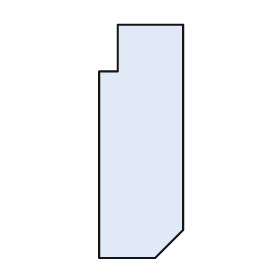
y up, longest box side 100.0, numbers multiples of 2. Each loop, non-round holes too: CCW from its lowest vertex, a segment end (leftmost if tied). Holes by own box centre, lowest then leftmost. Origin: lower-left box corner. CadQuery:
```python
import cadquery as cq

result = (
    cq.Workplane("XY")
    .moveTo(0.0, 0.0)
    .lineTo(24.0, 0.0)
    .lineTo(36.0, 12.0)
    .lineTo(36.0, 100.0)
    .lineTo(8.0, 100.0)
    .lineTo(8.0, 80.0)
    .lineTo(0.0, 80.0)
    .close()
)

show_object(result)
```